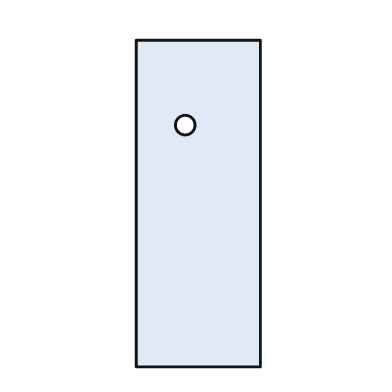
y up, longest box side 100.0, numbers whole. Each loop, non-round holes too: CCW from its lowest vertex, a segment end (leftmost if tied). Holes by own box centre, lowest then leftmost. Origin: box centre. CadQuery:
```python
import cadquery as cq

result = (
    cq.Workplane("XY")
    .moveTo(-19.0, -50.0)
    .lineTo(19.0, -50.0)
    .lineTo(19.0, 50.0)
    .lineTo(-19.0, 50.0)
    .close()
    .moveTo(-4.0, 24.0)
    .circle(3.0)
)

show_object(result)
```